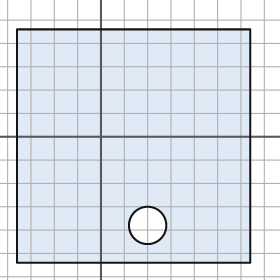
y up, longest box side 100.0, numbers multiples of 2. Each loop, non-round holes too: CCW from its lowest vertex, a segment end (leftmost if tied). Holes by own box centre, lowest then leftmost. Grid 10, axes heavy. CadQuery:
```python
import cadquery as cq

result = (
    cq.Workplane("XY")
    .moveTo(-36.0, -54.0)
    .lineTo(64.0, -54.0)
    .lineTo(64.0, 46.0)
    .lineTo(-36.0, 46.0)
    .close()
    .moveTo(20.0, -38.0)
    .circle(8.0)
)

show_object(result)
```